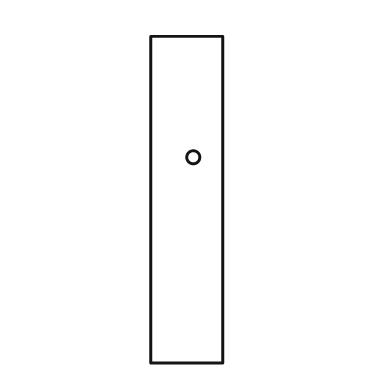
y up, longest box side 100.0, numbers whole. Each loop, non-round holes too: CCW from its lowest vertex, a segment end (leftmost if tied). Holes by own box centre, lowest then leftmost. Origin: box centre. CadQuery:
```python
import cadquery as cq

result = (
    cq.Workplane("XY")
    .moveTo(-11.0, -50.0)
    .lineTo(11.0, -50.0)
    .lineTo(11.0, 50.0)
    .lineTo(-11.0, 50.0)
    .close()
    .moveTo(2.0, 13.0)
    .circle(2.0)
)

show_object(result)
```